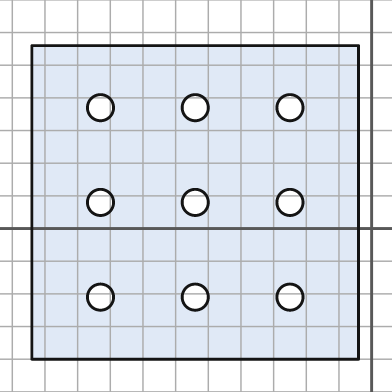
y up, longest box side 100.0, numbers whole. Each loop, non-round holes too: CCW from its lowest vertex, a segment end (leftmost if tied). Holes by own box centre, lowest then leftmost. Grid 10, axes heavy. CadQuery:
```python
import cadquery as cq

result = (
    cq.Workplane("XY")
    .moveTo(-104.0, -40.0)
    .lineTo(-4.0, -40.0)
    .lineTo(-4.0, 56.0)
    .lineTo(-104.0, 56.0)
    .close()
    .moveTo(-83.0, -21.0)
    .circle(4.0)
    .moveTo(-54.0, -21.0)
    .circle(4.0)
    .moveTo(-25.0, -21.0)
    .circle(4.0)
    .moveTo(-83.0, 8.0)
    .circle(4.0)
    .moveTo(-54.0, 8.0)
    .circle(4.0)
    .moveTo(-25.0, 8.0)
    .circle(4.0)
    .moveTo(-83.0, 37.0)
    .circle(4.0)
    .moveTo(-54.0, 37.0)
    .circle(4.0)
    .moveTo(-25.0, 37.0)
    .circle(4.0)
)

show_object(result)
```